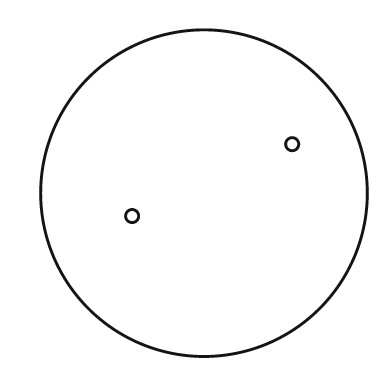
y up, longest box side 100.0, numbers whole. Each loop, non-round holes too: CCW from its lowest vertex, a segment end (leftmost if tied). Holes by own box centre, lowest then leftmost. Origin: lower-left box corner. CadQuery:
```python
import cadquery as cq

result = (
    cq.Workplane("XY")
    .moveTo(50.0, 50.0)
    .circle(50.0)
    .moveTo(28.0, 43.0)
    .circle(2.0)
    .moveTo(77.0, 65.0)
    .circle(2.0)
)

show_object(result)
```